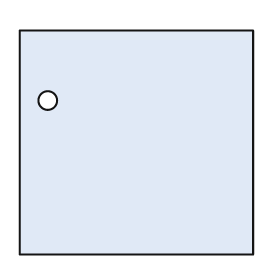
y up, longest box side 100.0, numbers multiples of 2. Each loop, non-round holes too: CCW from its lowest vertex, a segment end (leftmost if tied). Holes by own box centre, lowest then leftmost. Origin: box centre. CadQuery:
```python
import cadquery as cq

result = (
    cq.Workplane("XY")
    .moveTo(-50.0, -48.0)
    .lineTo(50.0, -48.0)
    .lineTo(50.0, 48.0)
    .lineTo(-50.0, 48.0)
    .close()
    .moveTo(-38.0, 18.0)
    .circle(4.0)
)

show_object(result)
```